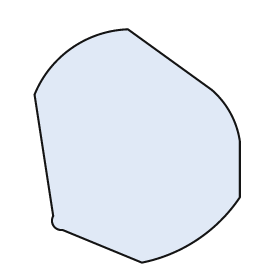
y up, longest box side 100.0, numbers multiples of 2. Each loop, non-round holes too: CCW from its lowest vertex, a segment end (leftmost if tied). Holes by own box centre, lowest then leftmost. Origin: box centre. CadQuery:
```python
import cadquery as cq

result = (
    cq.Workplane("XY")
    .moveTo(2.0, -50.0)
    .threePointArc((26.0, -40.0), (44.0, -22.0))
    .lineTo(44.0, 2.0)
    .threePointArc((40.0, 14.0), (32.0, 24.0))
    .lineTo(-4.0, 50.0)
    .threePointArc((-28.0, 42.0), (-44.0, 22.0))
    .lineTo(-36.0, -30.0)
    .threePointArc((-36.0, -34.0), (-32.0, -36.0))
    .close()
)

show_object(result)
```